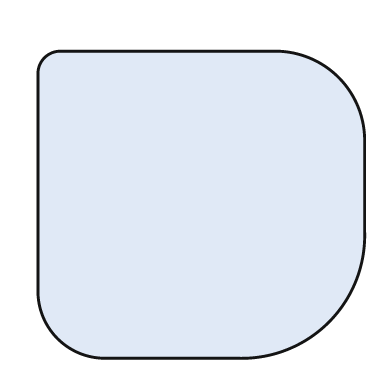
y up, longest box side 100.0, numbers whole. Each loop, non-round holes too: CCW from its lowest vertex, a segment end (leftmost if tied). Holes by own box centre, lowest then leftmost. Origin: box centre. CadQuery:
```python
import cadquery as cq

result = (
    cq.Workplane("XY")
    .moveTo(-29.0, -47.0)
    .lineTo(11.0, -47.0)
    .threePointArc((39.0, -36.0), (50.0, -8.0))
    .lineTo(50.0, 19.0)
    .threePointArc((42.0, 39.0), (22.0, 47.0))
    .lineTo(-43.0, 47.0)
    .threePointArc((-48.0, 45.0), (-50.0, 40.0))
    .lineTo(-50.0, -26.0)
    .threePointArc((-44.0, -41.0), (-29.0, -47.0))
    .close()
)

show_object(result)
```